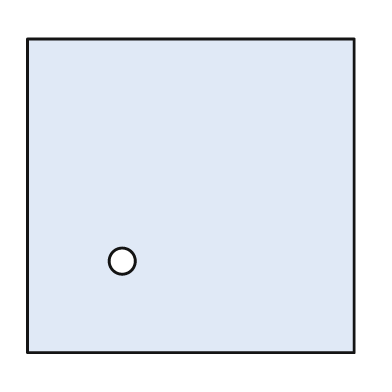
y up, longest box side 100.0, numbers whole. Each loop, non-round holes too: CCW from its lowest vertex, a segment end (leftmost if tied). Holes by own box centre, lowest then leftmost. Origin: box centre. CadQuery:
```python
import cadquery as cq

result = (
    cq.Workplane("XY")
    .moveTo(-50.0, -48.0)
    .lineTo(50.0, -48.0)
    .lineTo(50.0, 48.0)
    .lineTo(-50.0, 48.0)
    .close()
    .moveTo(-21.0, -20.0)
    .circle(4.0)
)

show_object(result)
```